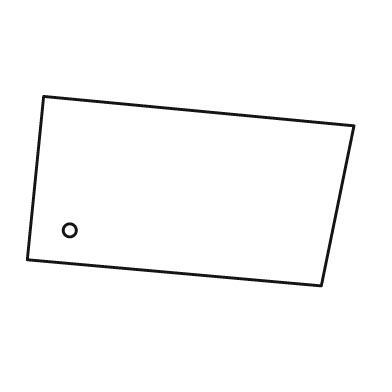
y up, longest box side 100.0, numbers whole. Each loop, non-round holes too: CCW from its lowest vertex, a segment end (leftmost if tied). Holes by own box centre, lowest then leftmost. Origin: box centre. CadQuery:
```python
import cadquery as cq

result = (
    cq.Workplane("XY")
    .moveTo(40.0, -29.0)
    .lineTo(50.0, 20.0)
    .lineTo(-45.0, 29.0)
    .lineTo(-50.0, -21.0)
    .close()
    .moveTo(-37.0, -12.0)
    .circle(2.0)
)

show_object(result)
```